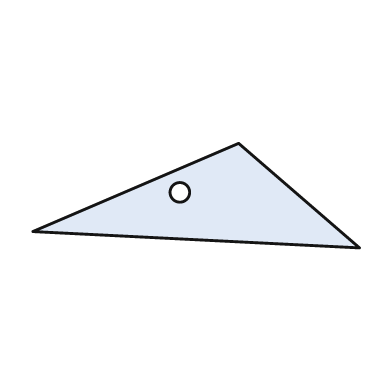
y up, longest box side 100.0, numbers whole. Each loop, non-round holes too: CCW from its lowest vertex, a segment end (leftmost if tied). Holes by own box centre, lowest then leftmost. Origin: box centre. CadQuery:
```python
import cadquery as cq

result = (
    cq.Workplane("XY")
    .moveTo(50.0, -16.0)
    .lineTo(13.0, 16.0)
    .lineTo(-50.0, -11.0)
    .close()
    .moveTo(-5.0, 1.0)
    .circle(3.0)
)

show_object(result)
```